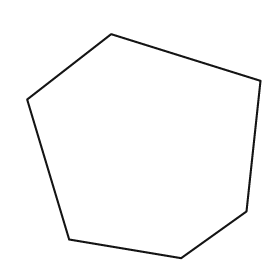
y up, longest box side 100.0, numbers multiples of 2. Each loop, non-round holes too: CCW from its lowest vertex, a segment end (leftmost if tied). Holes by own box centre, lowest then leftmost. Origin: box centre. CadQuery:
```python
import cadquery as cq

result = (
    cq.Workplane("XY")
    .moveTo(16.0, -48.0)
    .lineTo(44.0, -28.0)
    .lineTo(50.0, 28.0)
    .lineTo(-14.0, 48.0)
    .lineTo(-50.0, 20.0)
    .lineTo(-32.0, -40.0)
    .close()
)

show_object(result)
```